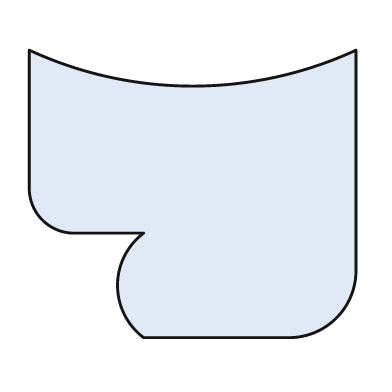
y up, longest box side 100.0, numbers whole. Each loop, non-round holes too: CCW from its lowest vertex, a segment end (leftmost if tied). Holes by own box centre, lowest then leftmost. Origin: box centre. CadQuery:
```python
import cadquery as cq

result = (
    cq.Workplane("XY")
    .moveTo(-15.0, -44.0)
    .lineTo(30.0, -44.0)
    .threePointArc((44.0, -38.0), (50.0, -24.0))
    .lineTo(50.0, 44.0)
    .threePointArc((0.0, 33.0), (-50.0, 44.0))
    .lineTo(-50.0, 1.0)
    .threePointArc((-46.0, -8.0), (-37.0, -12.0))
    .lineTo(-15.0, -12.0)
    .threePointArc((-23.0, -28.0), (-15.0, -44.0))
    .close()
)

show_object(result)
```